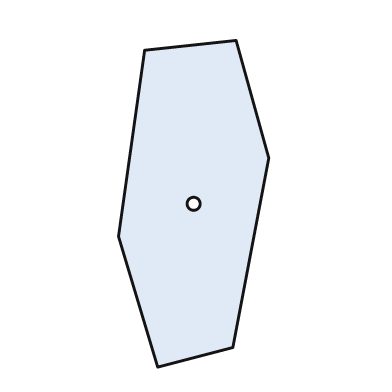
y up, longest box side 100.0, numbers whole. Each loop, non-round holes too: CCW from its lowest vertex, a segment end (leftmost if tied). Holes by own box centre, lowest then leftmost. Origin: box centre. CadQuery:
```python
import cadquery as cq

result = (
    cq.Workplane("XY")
    .moveTo(-11.0, -50.0)
    .lineTo(12.0, -44.0)
    .lineTo(23.0, 14.0)
    .lineTo(13.0, 50.0)
    .lineTo(-15.0, 47.0)
    .lineTo(-23.0, -10.0)
    .close()
    .moveTo(0.0, 0.0)
    .circle(2.0)
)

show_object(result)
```